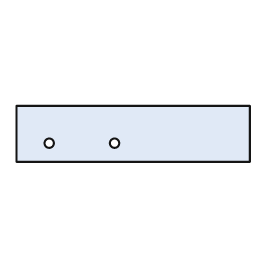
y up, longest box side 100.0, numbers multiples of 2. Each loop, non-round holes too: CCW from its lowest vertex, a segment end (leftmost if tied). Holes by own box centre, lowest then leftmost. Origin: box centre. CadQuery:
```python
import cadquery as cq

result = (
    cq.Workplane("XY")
    .moveTo(-50.0, -12.0)
    .lineTo(50.0, -12.0)
    .lineTo(50.0, 12.0)
    .lineTo(-50.0, 12.0)
    .close()
    .moveTo(-36.0, -4.0)
    .circle(2.0)
    .moveTo(-8.0, -4.0)
    .circle(2.0)
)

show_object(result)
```